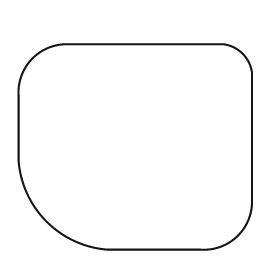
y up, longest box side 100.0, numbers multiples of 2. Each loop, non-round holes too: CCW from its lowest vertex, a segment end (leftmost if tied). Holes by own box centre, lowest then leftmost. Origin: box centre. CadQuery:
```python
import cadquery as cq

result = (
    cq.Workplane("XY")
    .moveTo(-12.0, -44.0)
    .lineTo(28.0, -44.0)
    .threePointArc((44.0, -38.0), (50.0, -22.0))
    .lineTo(50.0, 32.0)
    .threePointArc((46.0, 40.0), (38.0, 44.0))
    .lineTo(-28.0, 44.0)
    .threePointArc((-44.0, 38.0), (-50.0, 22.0))
    .lineTo(-50.0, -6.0)
    .threePointArc((-38.0, -32.0), (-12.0, -44.0))
    .close()
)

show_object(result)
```